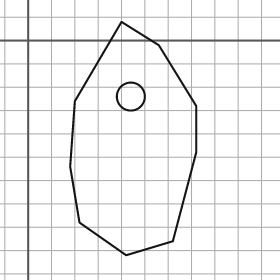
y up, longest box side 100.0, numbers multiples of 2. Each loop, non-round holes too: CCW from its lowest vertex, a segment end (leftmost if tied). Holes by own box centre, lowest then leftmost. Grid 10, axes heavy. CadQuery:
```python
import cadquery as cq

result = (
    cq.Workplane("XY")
    .moveTo(42.0, -92.0)
    .lineTo(62.0, -86.0)
    .lineTo(72.0, -48.0)
    .lineTo(72.0, -28.0)
    .lineTo(56.0, -2.0)
    .lineTo(40.0, 8.0)
    .lineTo(20.0, -26.0)
    .lineTo(18.0, -54.0)
    .lineTo(22.0, -78.0)
    .close()
    .moveTo(44.0, -24.0)
    .circle(6.0)
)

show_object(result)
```